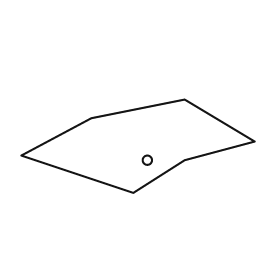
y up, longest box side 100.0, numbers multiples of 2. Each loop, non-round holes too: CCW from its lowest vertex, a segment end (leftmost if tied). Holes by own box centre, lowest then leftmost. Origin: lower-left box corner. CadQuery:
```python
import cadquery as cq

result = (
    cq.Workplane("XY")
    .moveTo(48.0, 0.0)
    .lineTo(70.0, 14.0)
    .lineTo(100.0, 22.0)
    .lineTo(70.0, 40.0)
    .lineTo(30.0, 32.0)
    .lineTo(0.0, 16.0)
    .close()
    .moveTo(54.0, 14.0)
    .circle(2.0)
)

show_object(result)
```